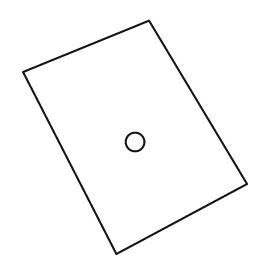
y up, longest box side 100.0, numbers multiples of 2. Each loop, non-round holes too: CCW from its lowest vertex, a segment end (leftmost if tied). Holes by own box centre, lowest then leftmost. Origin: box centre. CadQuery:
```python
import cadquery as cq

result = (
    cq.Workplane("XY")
    .moveTo(-8.0, -50.0)
    .lineTo(48.0, -20.0)
    .lineTo(6.0, 50.0)
    .lineTo(-48.0, 28.0)
    .close()
    .moveTo(0.0, -2.0)
    .circle(4.0)
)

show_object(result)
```